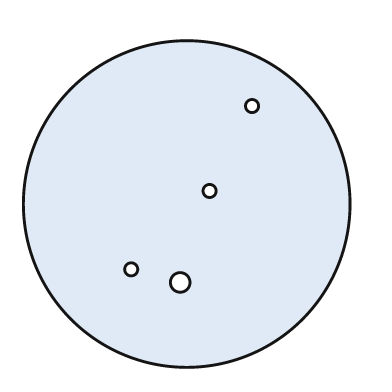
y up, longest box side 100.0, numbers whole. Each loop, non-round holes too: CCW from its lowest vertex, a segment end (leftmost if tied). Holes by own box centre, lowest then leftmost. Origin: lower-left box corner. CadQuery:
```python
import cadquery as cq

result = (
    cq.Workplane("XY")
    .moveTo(50.0, 50.0)
    .circle(50.0)
    .moveTo(48.0, 26.0)
    .circle(3.0)
    .moveTo(33.0, 30.0)
    .circle(2.0)
    .moveTo(57.0, 54.0)
    .circle(2.0)
    .moveTo(70.0, 80.0)
    .circle(2.0)
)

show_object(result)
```